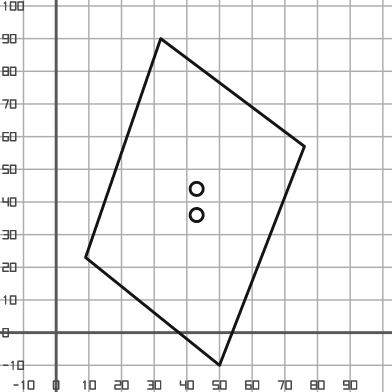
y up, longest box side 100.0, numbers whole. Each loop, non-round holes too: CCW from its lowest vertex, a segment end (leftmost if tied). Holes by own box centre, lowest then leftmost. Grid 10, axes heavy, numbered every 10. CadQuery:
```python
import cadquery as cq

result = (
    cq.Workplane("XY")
    .moveTo(50.0, -10.0)
    .lineTo(76.0, 57.0)
    .lineTo(32.0, 90.0)
    .lineTo(9.0, 23.0)
    .close()
    .moveTo(43.0, 36.0)
    .circle(2.0)
    .moveTo(43.0, 44.0)
    .circle(2.0)
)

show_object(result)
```